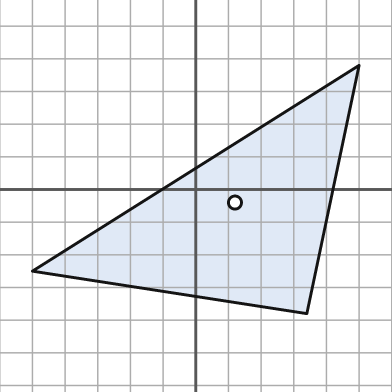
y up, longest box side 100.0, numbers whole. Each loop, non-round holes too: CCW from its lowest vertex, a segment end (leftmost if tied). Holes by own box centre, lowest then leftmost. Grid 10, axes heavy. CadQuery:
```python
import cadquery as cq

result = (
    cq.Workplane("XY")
    .moveTo(34.0, -38.0)
    .lineTo(50.0, 38.0)
    .lineTo(-50.0, -25.0)
    .close()
    .moveTo(12.0, -4.0)
    .circle(2.0)
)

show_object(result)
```